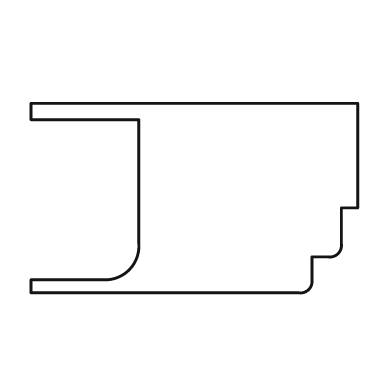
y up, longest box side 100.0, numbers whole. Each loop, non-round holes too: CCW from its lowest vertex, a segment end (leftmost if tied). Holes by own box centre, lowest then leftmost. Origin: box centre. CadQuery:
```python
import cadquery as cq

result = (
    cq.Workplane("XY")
    .moveTo(-50.0, -29.0)
    .lineTo(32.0, -29.0)
    .threePointArc((35.0, -28.0), (36.0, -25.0))
    .lineTo(36.0, -18.0)
    .lineTo(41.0, -18.0)
    .threePointArc((44.0, -17.0), (45.0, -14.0))
    .lineTo(45.0, -3.0)
    .lineTo(50.0, -3.0)
    .lineTo(50.0, 29.0)
    .lineTo(-50.0, 29.0)
    .lineTo(-50.0, 24.0)
    .lineTo(-17.0, 24.0)
    .lineTo(-17.0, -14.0)
    .threePointArc((-20.0, -22.0), (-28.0, -25.0))
    .lineTo(-50.0, -25.0)
    .close()
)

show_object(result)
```